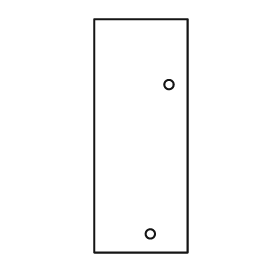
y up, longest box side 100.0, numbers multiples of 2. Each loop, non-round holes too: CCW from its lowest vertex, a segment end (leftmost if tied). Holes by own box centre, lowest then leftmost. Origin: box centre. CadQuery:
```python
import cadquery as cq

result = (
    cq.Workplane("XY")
    .moveTo(-20.0, -50.0)
    .lineTo(20.0, -50.0)
    .lineTo(20.0, 50.0)
    .lineTo(-20.0, 50.0)
    .close()
    .moveTo(4.0, -42.0)
    .circle(2.0)
    .moveTo(12.0, 22.0)
    .circle(2.0)
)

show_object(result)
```